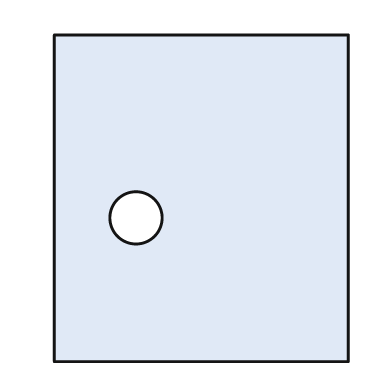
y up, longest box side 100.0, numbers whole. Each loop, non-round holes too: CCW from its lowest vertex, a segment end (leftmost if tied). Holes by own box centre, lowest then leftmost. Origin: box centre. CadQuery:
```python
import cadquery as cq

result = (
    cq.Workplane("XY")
    .moveTo(-45.0, -50.0)
    .lineTo(45.0, -50.0)
    .lineTo(45.0, 50.0)
    .lineTo(-45.0, 50.0)
    .close()
    .moveTo(-20.0, -6.0)
    .circle(8.0)
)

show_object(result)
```